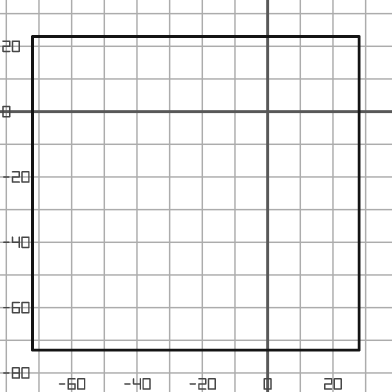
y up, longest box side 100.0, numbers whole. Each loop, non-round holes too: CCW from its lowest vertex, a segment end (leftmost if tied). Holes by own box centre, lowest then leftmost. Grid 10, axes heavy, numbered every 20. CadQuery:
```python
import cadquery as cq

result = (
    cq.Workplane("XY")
    .moveTo(-72.0, -73.0)
    .lineTo(28.0, -73.0)
    .lineTo(28.0, 23.0)
    .lineTo(-72.0, 23.0)
    .close()
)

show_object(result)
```